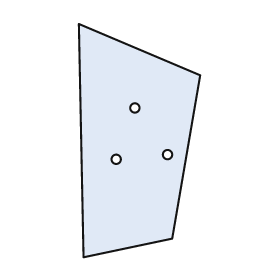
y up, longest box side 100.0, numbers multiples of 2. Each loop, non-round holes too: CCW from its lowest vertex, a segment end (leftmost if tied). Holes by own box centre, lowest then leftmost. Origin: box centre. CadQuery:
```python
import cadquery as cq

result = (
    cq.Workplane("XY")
    .moveTo(-24.0, -50.0)
    .lineTo(14.0, -42.0)
    .lineTo(26.0, 28.0)
    .lineTo(-26.0, 50.0)
    .close()
    .moveTo(-10.0, -8.0)
    .circle(2.0)
    .moveTo(12.0, -6.0)
    .circle(2.0)
    .moveTo(-2.0, 14.0)
    .circle(2.0)
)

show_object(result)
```